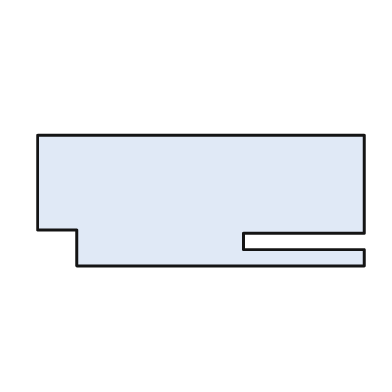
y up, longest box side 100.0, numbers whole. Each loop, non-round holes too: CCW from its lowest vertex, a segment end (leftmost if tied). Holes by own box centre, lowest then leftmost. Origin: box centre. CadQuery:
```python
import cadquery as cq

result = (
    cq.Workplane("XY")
    .moveTo(-38.0, -20.0)
    .lineTo(50.0, -20.0)
    .lineTo(50.0, -15.0)
    .lineTo(13.0, -15.0)
    .lineTo(13.0, -10.0)
    .lineTo(50.0, -10.0)
    .lineTo(50.0, 20.0)
    .lineTo(-50.0, 20.0)
    .lineTo(-50.0, -9.0)
    .lineTo(-38.0, -9.0)
    .close()
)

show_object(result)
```